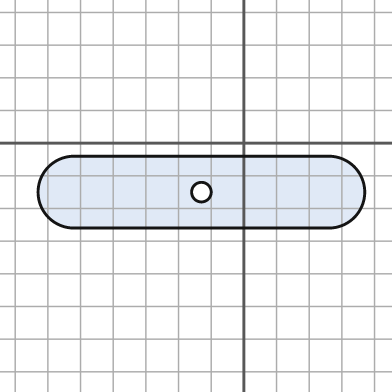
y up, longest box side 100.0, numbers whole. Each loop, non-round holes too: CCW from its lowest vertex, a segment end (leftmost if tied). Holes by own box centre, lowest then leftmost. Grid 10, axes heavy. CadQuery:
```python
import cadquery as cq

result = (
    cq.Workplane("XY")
    .moveTo(-52.0, -26.0)
    .lineTo(26.0, -26.0)
    .threePointArc((37.0, -15.0), (26.0, -4.0))
    .lineTo(-52.0, -4.0)
    .threePointArc((-63.0, -15.0), (-52.0, -26.0))
    .close()
    .moveTo(-13.0, -15.0)
    .circle(3.0)
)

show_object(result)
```